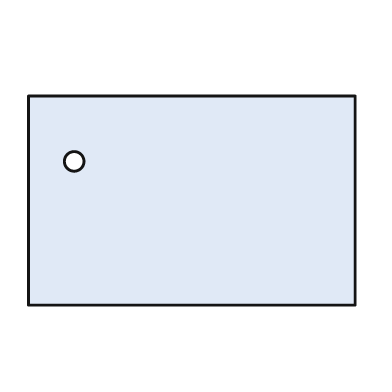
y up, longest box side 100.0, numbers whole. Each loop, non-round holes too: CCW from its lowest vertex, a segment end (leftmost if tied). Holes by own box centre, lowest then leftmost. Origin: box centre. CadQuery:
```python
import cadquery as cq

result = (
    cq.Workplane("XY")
    .moveTo(-50.0, -32.0)
    .lineTo(50.0, -32.0)
    .lineTo(50.0, 32.0)
    .lineTo(-50.0, 32.0)
    .close()
    .moveTo(-36.0, 12.0)
    .circle(3.0)
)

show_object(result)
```